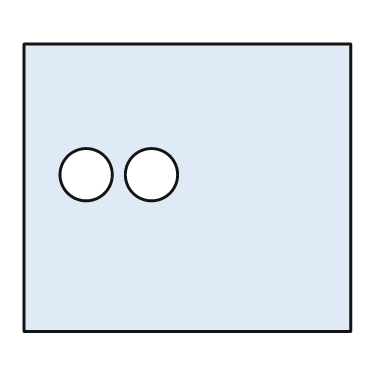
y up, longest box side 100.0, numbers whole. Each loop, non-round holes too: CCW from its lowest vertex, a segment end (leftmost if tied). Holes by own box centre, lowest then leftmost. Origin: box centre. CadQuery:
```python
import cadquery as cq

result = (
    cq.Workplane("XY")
    .moveTo(-50.0, -44.0)
    .lineTo(50.0, -44.0)
    .lineTo(50.0, 44.0)
    .lineTo(-50.0, 44.0)
    .close()
    .moveTo(-31.0, 4.0)
    .circle(8.0)
    .moveTo(-11.0, 4.0)
    .circle(8.0)
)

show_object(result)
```